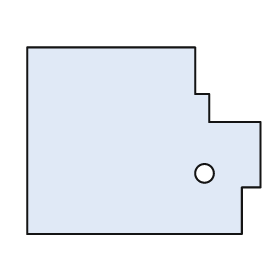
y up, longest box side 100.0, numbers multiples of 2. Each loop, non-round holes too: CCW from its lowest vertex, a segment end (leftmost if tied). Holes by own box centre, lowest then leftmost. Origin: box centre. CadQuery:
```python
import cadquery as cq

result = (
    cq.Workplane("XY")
    .moveTo(-50.0, -40.0)
    .lineTo(42.0, -40.0)
    .lineTo(42.0, -20.0)
    .lineTo(50.0, -20.0)
    .lineTo(50.0, 8.0)
    .lineTo(28.0, 8.0)
    .lineTo(28.0, 20.0)
    .lineTo(22.0, 20.0)
    .lineTo(22.0, 40.0)
    .lineTo(-50.0, 40.0)
    .close()
    .moveTo(26.0, -14.0)
    .circle(4.0)
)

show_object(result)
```